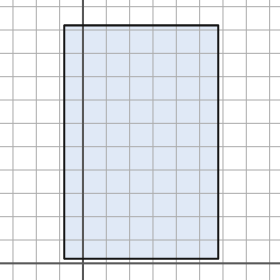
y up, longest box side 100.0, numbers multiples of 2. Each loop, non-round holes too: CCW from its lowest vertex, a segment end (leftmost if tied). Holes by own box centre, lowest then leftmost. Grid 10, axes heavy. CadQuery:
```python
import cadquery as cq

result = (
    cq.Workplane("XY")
    .moveTo(-8.0, 2.0)
    .lineTo(58.0, 2.0)
    .lineTo(58.0, 102.0)
    .lineTo(-8.0, 102.0)
    .close()
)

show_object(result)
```